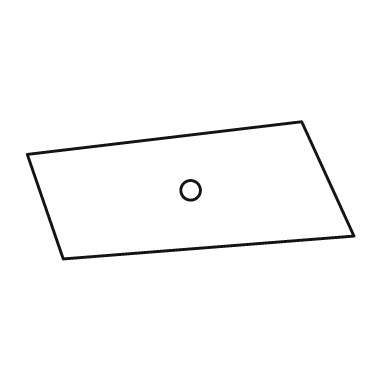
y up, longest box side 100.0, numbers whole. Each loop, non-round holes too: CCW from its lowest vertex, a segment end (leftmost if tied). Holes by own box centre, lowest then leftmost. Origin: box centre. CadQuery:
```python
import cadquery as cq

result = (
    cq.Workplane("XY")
    .moveTo(-39.0, -21.0)
    .lineTo(50.0, -14.0)
    .lineTo(34.0, 21.0)
    .lineTo(-50.0, 11.0)
    .close()
    .moveTo(0.0, 0.0)
    .circle(3.0)
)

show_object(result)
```